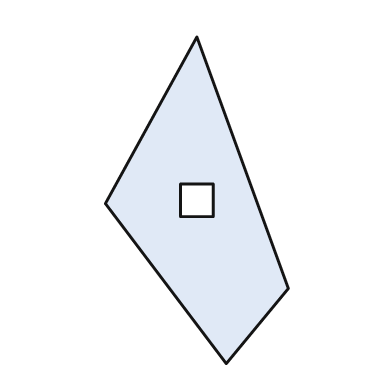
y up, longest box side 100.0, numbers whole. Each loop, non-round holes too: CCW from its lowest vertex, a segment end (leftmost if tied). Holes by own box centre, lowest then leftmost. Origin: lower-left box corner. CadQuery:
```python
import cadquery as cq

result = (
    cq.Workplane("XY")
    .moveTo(37.0, 0.0)
    .lineTo(56.0, 23.0)
    .lineTo(28.0, 100.0)
    .lineTo(0.0, 49.0)
    .close()
    .moveTo(23.0, 45.0)
    .lineTo(33.0, 45.0)
    .lineTo(33.0, 55.0)
    .lineTo(23.0, 55.0)
    .close()
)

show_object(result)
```